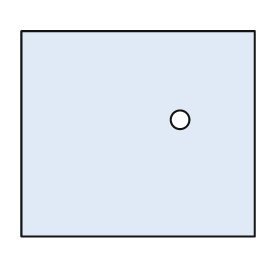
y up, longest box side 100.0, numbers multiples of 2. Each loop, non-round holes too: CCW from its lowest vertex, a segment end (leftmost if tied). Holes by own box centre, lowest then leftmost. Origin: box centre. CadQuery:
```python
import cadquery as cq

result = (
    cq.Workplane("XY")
    .moveTo(-50.0, -44.0)
    .lineTo(50.0, -44.0)
    .lineTo(50.0, 44.0)
    .lineTo(-50.0, 44.0)
    .close()
    .moveTo(18.0, 6.0)
    .circle(4.0)
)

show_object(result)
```